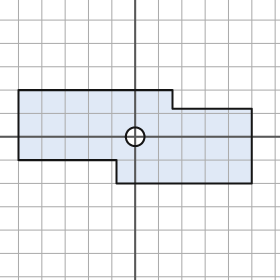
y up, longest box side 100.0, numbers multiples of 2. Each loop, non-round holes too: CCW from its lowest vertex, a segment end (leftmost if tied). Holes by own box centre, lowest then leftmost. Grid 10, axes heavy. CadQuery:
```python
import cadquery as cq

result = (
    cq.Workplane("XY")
    .moveTo(-8.0, -20.0)
    .lineTo(50.0, -20.0)
    .lineTo(50.0, 12.0)
    .lineTo(16.0, 12.0)
    .lineTo(16.0, 20.0)
    .lineTo(-50.0, 20.0)
    .lineTo(-50.0, -10.0)
    .lineTo(-8.0, -10.0)
    .close()
    .moveTo(0.0, 0.0)
    .circle(4.0)
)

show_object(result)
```